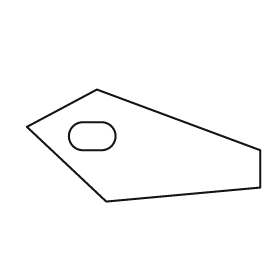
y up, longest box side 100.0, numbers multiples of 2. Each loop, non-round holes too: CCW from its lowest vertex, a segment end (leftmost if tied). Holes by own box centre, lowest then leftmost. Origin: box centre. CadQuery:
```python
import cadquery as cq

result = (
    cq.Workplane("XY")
    .moveTo(-16.0, -24.0)
    .lineTo(50.0, -18.0)
    .lineTo(50.0, -2.0)
    .lineTo(-20.0, 24.0)
    .lineTo(-50.0, 8.0)
    .close()
    .moveTo(-26.0, -2.0)
    .lineTo(-18.0, -2.0)
    .threePointArc((-12.0, 4.0), (-18.0, 10.0))
    .lineTo(-26.0, 10.0)
    .threePointArc((-32.0, 4.0), (-26.0, -2.0))
    .close()
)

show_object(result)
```